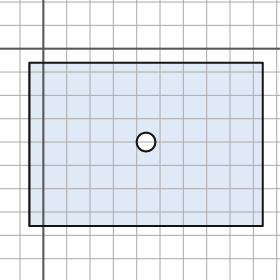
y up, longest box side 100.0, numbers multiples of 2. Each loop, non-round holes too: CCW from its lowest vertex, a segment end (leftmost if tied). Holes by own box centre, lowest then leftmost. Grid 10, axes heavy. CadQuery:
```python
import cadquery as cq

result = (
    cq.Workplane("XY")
    .moveTo(-6.0, -76.0)
    .lineTo(94.0, -76.0)
    .lineTo(94.0, -6.0)
    .lineTo(-6.0, -6.0)
    .close()
    .moveTo(44.0, -40.0)
    .circle(4.0)
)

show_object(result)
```